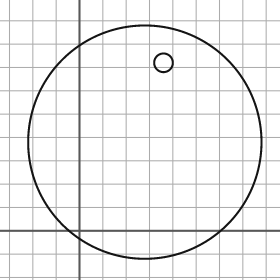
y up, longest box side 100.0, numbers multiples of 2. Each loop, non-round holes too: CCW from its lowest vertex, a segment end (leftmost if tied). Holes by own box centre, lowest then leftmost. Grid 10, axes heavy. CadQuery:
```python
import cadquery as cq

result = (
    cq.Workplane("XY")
    .moveTo(28.0, 38.0)
    .circle(50.0)
    .moveTo(36.0, 72.0)
    .circle(4.0)
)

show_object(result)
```